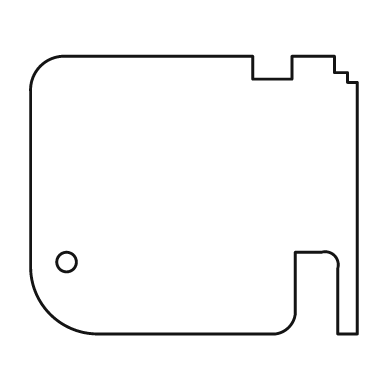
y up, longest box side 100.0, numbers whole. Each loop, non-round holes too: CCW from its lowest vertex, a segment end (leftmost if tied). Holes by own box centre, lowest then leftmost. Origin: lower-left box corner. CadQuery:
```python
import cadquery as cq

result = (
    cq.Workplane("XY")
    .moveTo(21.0, 0.0)
    .lineTo(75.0, 0.0)
    .threePointArc((79.0, 2.0), (81.0, 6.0))
    .lineTo(81.0, 25.0)
    .lineTo(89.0, 25.0)
    .threePointArc((93.0, 24.0), (94.0, 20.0))
    .lineTo(94.0, 0.0)
    .lineTo(100.0, 0.0)
    .lineTo(100.0, 77.0)
    .lineTo(97.0, 77.0)
    .lineTo(97.0, 80.0)
    .lineTo(93.0, 80.0)
    .lineTo(93.0, 85.0)
    .lineTo(80.0, 85.0)
    .lineTo(80.0, 78.0)
    .lineTo(68.0, 78.0)
    .lineTo(68.0, 85.0)
    .lineTo(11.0, 85.0)
    .threePointArc((3.0, 82.0), (0.0, 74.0))
    .lineTo(0.0, 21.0)
    .threePointArc((6.0, 6.0), (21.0, 0.0))
    .close()
    .moveTo(11.0, 22.0)
    .circle(3.0)
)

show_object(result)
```